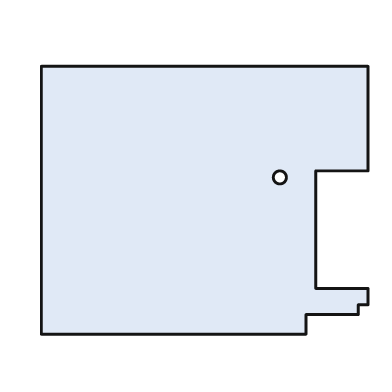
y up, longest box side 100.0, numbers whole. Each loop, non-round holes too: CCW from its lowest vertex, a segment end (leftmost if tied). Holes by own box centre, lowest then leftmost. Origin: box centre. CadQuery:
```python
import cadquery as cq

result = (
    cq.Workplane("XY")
    .moveTo(-50.0, -41.0)
    .lineTo(31.0, -41.0)
    .lineTo(31.0, -35.0)
    .lineTo(47.0, -35.0)
    .lineTo(47.0, -32.0)
    .lineTo(50.0, -32.0)
    .lineTo(50.0, -27.0)
    .lineTo(34.0, -27.0)
    .lineTo(34.0, 9.0)
    .lineTo(50.0, 9.0)
    .lineTo(50.0, 41.0)
    .lineTo(-50.0, 41.0)
    .close()
    .moveTo(23.0, 7.0)
    .circle(2.0)
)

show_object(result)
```